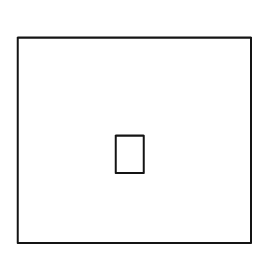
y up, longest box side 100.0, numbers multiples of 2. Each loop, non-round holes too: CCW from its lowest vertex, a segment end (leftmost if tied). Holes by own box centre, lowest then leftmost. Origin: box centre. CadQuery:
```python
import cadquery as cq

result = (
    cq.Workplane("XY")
    .moveTo(-50.0, -44.0)
    .lineTo(50.0, -44.0)
    .lineTo(50.0, 44.0)
    .lineTo(-50.0, 44.0)
    .close()
    .moveTo(-8.0, -14.0)
    .lineTo(4.0, -14.0)
    .lineTo(4.0, 2.0)
    .lineTo(-8.0, 2.0)
    .close()
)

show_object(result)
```